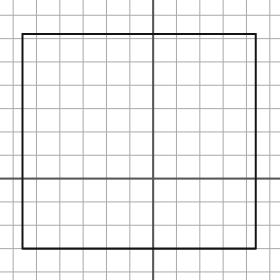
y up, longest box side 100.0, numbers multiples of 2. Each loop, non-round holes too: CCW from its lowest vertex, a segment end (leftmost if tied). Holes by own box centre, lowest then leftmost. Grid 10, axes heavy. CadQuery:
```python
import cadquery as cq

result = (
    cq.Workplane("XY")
    .moveTo(-56.0, -30.0)
    .lineTo(44.0, -30.0)
    .lineTo(44.0, 62.0)
    .lineTo(-56.0, 62.0)
    .close()
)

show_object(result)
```